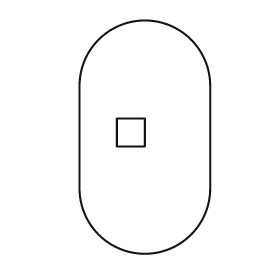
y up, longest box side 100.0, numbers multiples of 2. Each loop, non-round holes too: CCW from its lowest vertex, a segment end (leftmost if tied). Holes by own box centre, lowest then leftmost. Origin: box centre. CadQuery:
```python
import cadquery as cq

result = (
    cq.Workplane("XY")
    .moveTo(-28.0, -22.0)
    .threePointArc((0.0, -50.0), (28.0, -22.0))
    .lineTo(28.0, 22.0)
    .threePointArc((0.0, 50.0), (-28.0, 22.0))
    .close()
    .moveTo(-12.0, -4.0)
    .lineTo(0.0, -4.0)
    .lineTo(0.0, 8.0)
    .lineTo(-12.0, 8.0)
    .close()
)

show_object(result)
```